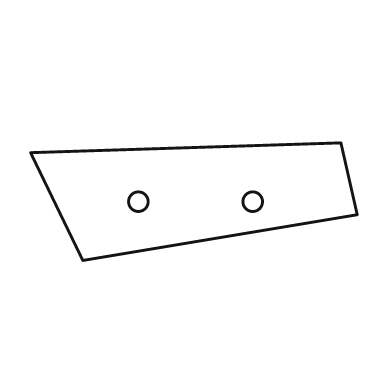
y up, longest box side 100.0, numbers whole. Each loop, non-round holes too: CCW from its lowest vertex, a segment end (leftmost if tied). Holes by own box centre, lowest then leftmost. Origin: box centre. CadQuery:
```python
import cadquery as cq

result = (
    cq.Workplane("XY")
    .moveTo(-34.0, -18.0)
    .lineTo(50.0, -4.0)
    .lineTo(45.0, 18.0)
    .lineTo(-50.0, 15.0)
    .close()
    .moveTo(-17.0, 0.0)
    .circle(3.0)
    .moveTo(18.0, 0.0)
    .circle(3.0)
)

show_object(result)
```